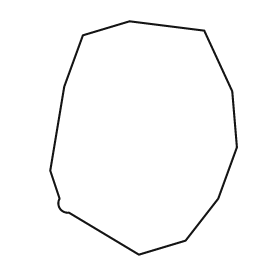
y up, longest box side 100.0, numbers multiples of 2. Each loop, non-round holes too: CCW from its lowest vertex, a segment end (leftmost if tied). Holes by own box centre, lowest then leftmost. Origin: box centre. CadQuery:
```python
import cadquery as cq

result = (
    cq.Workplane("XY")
    .moveTo(-2.0, -50.0)
    .lineTo(18.0, -44.0)
    .lineTo(32.0, -26.0)
    .lineTo(40.0, -4.0)
    .lineTo(38.0, 20.0)
    .lineTo(26.0, 46.0)
    .lineTo(-6.0, 50.0)
    .lineTo(-26.0, 44.0)
    .lineTo(-34.0, 22.0)
    .lineTo(-40.0, -14.0)
    .lineTo(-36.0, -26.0)
    .threePointArc((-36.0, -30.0), (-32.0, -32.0))
    .close()
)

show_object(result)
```